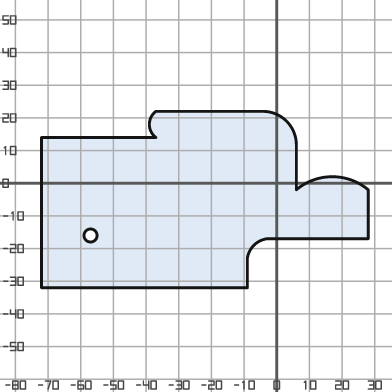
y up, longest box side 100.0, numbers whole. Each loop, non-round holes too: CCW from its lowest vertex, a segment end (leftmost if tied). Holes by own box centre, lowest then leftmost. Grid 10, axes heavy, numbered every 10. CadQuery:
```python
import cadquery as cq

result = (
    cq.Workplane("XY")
    .moveTo(-72.0, -32.0)
    .lineTo(-9.0, -32.0)
    .lineTo(-9.0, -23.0)
    .threePointArc((-7.0, -19.0), (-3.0, -17.0))
    .lineTo(28.0, -17.0)
    .lineTo(28.0, -2.0)
    .threePointArc((17.0, 2.0), (6.0, -2.0))
    .lineTo(6.0, 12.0)
    .threePointArc((3.0, 19.0), (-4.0, 22.0))
    .lineTo(-37.0, 22.0)
    .threePointArc((-39.0, 18.0), (-37.0, 14.0))
    .lineTo(-72.0, 14.0)
    .close()
    .moveTo(-57.0, -16.0)
    .circle(2.0)
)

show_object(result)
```